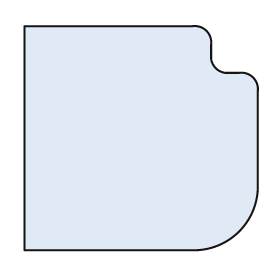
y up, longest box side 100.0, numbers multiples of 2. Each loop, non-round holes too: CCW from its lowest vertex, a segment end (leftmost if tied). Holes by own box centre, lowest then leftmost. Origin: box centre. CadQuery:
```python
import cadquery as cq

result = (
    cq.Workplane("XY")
    .moveTo(-50.0, -48.0)
    .lineTo(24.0, -48.0)
    .threePointArc((42.0, -40.0), (50.0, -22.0))
    .lineTo(50.0, 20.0)
    .threePointArc((48.0, 26.0), (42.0, 28.0))
    .lineTo(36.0, 28.0)
    .threePointArc((32.0, 30.0), (30.0, 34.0))
    .lineTo(30.0, 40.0)
    .threePointArc((28.0, 46.0), (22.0, 48.0))
    .lineTo(-50.0, 48.0)
    .close()
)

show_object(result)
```